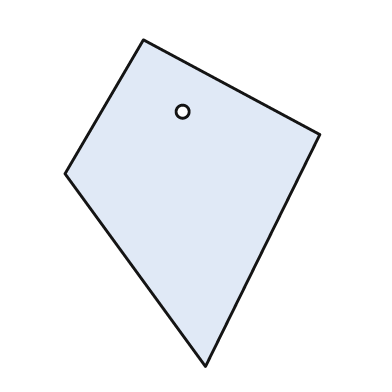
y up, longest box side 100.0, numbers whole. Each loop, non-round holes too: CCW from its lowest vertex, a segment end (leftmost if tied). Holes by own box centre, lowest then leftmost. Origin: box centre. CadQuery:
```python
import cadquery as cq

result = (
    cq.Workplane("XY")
    .moveTo(4.0, -50.0)
    .lineTo(39.0, 21.0)
    .lineTo(-15.0, 50.0)
    .lineTo(-39.0, 9.0)
    .close()
    .moveTo(-3.0, 28.0)
    .circle(2.0)
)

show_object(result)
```